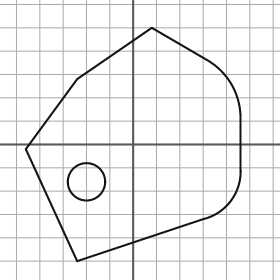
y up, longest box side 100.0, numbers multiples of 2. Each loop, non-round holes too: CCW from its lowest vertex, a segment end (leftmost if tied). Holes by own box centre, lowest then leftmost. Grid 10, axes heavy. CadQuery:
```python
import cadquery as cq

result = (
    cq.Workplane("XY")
    .moveTo(-24.0, -50.0)
    .lineTo(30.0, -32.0)
    .threePointArc((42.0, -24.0), (46.0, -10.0))
    .lineTo(46.0, 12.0)
    .threePointArc((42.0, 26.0), (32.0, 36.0))
    .lineTo(8.0, 50.0)
    .lineTo(-24.0, 28.0)
    .lineTo(-46.0, -2.0)
    .close()
    .moveTo(-20.0, -16.0)
    .circle(8.0)
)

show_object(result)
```